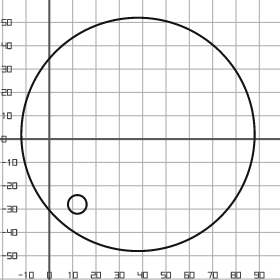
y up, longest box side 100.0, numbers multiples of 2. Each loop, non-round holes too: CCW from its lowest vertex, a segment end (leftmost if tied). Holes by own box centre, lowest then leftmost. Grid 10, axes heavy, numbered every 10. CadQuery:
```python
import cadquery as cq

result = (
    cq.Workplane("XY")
    .moveTo(38.0, 2.0)
    .circle(50.0)
    .moveTo(12.0, -28.0)
    .circle(4.0)
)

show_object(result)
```